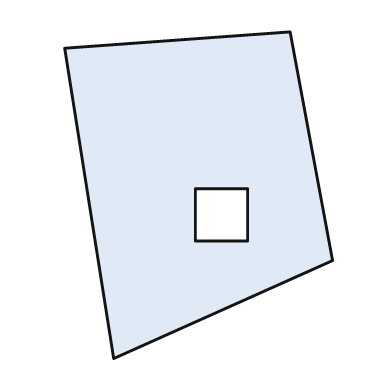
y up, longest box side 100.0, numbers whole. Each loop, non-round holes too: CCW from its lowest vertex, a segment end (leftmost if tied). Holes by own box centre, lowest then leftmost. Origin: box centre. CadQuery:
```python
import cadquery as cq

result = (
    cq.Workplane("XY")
    .moveTo(-26.0, -50.0)
    .lineTo(41.0, -20.0)
    .lineTo(28.0, 50.0)
    .lineTo(-41.0, 45.0)
    .close()
    .moveTo(-1.0, -14.0)
    .lineTo(15.0, -14.0)
    .lineTo(15.0, 2.0)
    .lineTo(-1.0, 2.0)
    .close()
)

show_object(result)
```